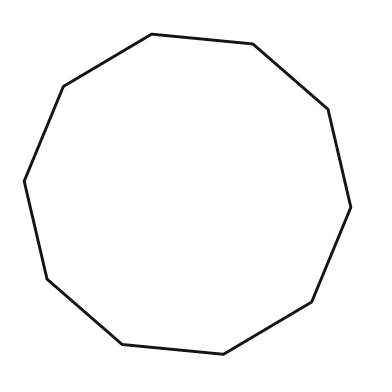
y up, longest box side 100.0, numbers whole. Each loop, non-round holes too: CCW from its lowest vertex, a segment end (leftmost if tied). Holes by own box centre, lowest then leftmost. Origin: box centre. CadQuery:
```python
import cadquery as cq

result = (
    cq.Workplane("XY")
    .moveTo(11.0, -49.0)
    .lineTo(38.0, -33.0)
    .lineTo(50.0, -4.0)
    .lineTo(43.0, 26.0)
    .lineTo(20.0, 46.0)
    .lineTo(-11.0, 49.0)
    .lineTo(-38.0, 33.0)
    .lineTo(-50.0, 4.0)
    .lineTo(-43.0, -26.0)
    .lineTo(-20.0, -46.0)
    .close()
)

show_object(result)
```